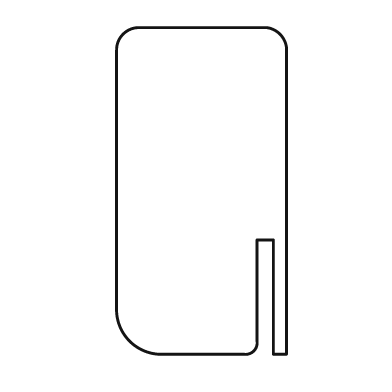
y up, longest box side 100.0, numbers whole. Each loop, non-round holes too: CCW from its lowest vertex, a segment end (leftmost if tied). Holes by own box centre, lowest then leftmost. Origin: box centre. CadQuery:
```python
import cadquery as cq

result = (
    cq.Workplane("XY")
    .moveTo(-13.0, -50.0)
    .lineTo(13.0, -50.0)
    .threePointArc((16.0, -49.0), (17.0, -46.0))
    .lineTo(17.0, -15.0)
    .lineTo(22.0, -15.0)
    .lineTo(22.0, -50.0)
    .lineTo(26.0, -50.0)
    .lineTo(26.0, 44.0)
    .threePointArc((24.0, 48.0), (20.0, 50.0))
    .lineTo(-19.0, 50.0)
    .threePointArc((-24.0, 48.0), (-26.0, 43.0))
    .lineTo(-26.0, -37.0)
    .threePointArc((-22.0, -46.0), (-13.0, -50.0))
    .close()
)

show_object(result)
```